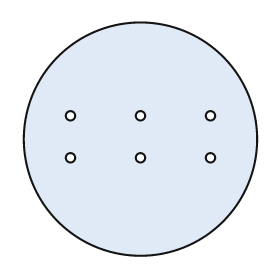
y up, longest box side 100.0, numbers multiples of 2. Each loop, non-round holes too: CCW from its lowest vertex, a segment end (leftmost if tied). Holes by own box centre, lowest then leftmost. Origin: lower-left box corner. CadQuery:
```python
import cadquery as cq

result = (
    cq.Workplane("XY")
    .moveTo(50.0, 50.0)
    .circle(50.0)
    .moveTo(20.0, 42.0)
    .circle(2.0)
    .moveTo(50.0, 42.0)
    .circle(2.0)
    .moveTo(80.0, 42.0)
    .circle(2.0)
    .moveTo(20.0, 60.0)
    .circle(2.0)
    .moveTo(50.0, 60.0)
    .circle(2.0)
    .moveTo(80.0, 60.0)
    .circle(2.0)
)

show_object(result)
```